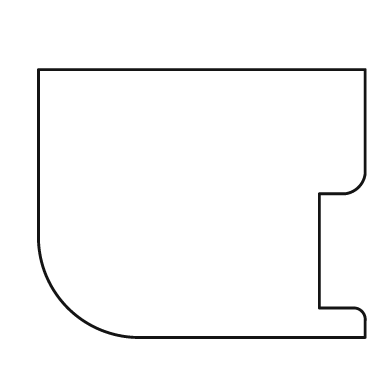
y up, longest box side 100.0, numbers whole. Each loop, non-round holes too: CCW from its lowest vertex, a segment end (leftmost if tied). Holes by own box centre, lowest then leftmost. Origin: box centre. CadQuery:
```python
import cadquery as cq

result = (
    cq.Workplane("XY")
    .moveTo(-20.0, -41.0)
    .lineTo(50.0, -41.0)
    .lineTo(50.0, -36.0)
    .threePointArc((49.0, -33.0), (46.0, -32.0))
    .lineTo(36.0, -32.0)
    .lineTo(36.0, 3.0)
    .lineTo(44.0, 3.0)
    .threePointArc((48.0, 5.0), (50.0, 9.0))
    .lineTo(50.0, 41.0)
    .lineTo(-50.0, 41.0)
    .lineTo(-50.0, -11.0)
    .threePointArc((-41.0, -32.0), (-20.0, -41.0))
    .close()
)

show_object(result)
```